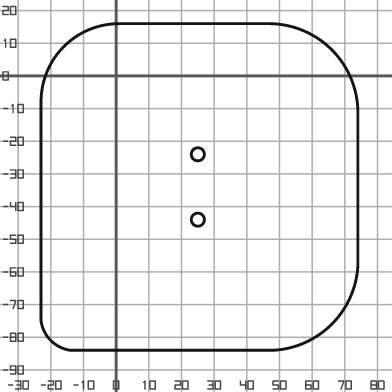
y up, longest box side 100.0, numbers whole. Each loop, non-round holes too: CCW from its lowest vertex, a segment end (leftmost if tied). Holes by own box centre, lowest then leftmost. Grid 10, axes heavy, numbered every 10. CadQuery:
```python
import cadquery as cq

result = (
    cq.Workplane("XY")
    .moveTo(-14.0, -84.0)
    .lineTo(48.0, -84.0)
    .threePointArc((66.0, -76.0), (74.0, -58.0))
    .lineTo(74.0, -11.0)
    .threePointArc((66.0, 8.0), (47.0, 16.0))
    .lineTo(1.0, 16.0)
    .threePointArc((-16.0, 9.0), (-23.0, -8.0))
    .lineTo(-23.0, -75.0)
    .threePointArc((-20.0, -81.0), (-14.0, -84.0))
    .close()
    .moveTo(25.0, -44.0)
    .circle(2.0)
    .moveTo(25.0, -24.0)
    .circle(2.0)
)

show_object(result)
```